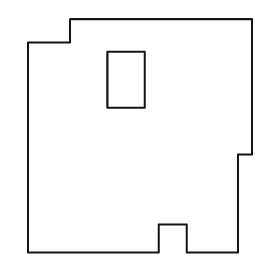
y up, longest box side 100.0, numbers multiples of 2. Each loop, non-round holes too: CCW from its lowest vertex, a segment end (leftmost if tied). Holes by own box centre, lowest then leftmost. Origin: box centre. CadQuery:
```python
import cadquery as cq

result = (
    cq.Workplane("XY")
    .moveTo(-48.0, -50.0)
    .lineTo(8.0, -50.0)
    .lineTo(8.0, -38.0)
    .lineTo(20.0, -38.0)
    .lineTo(20.0, -50.0)
    .lineTo(42.0, -50.0)
    .lineTo(42.0, -8.0)
    .lineTo(48.0, -8.0)
    .lineTo(48.0, 50.0)
    .lineTo(-30.0, 50.0)
    .lineTo(-30.0, 40.0)
    .lineTo(-48.0, 40.0)
    .close()
    .moveTo(-14.0, 12.0)
    .lineTo(2.0, 12.0)
    .lineTo(2.0, 36.0)
    .lineTo(-14.0, 36.0)
    .close()
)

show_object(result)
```